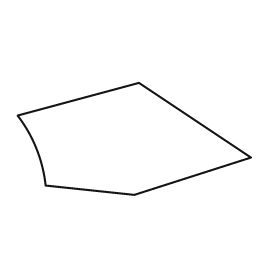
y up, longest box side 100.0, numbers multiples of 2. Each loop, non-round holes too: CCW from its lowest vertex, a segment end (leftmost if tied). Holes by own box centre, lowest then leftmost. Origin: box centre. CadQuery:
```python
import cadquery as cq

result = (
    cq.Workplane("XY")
    .moveTo(0.0, -24.0)
    .lineTo(50.0, -8.0)
    .lineTo(2.0, 24.0)
    .lineTo(-50.0, 10.0)
    .threePointArc((-42.0, -4.0), (-38.0, -20.0))
    .close()
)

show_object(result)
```